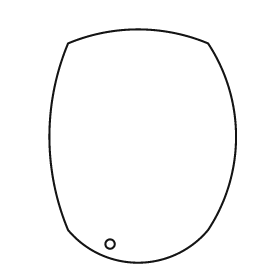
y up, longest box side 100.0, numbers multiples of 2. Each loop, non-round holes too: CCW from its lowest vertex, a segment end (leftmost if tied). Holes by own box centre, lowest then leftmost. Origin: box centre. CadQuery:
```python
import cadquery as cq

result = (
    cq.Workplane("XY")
    .moveTo(-32.0, -36.0)
    .threePointArc((-2.0, -50.0), (28.0, -36.0))
    .threePointArc((40.0, 4.0), (28.0, 44.0))
    .threePointArc((-2.0, 50.0), (-32.0, 44.0))
    .threePointArc((-40.0, 4.0), (-32.0, -36.0))
    .close()
    .moveTo(-14.0, -42.0)
    .circle(2.0)
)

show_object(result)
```